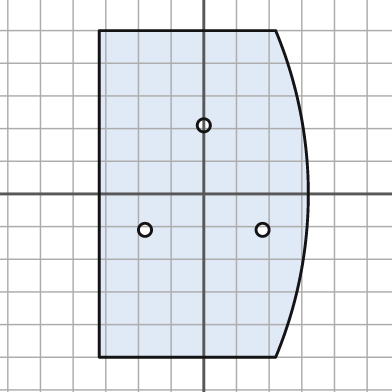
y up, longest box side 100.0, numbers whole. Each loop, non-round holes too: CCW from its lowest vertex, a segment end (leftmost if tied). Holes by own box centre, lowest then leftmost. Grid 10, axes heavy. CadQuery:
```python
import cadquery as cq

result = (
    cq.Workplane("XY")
    .moveTo(-32.0, -50.0)
    .lineTo(22.0, -50.0)
    .threePointArc((32.0, 0.0), (22.0, 50.0))
    .lineTo(-32.0, 50.0)
    .close()
    .moveTo(-18.0, -11.0)
    .circle(2.0)
    .moveTo(18.0, -11.0)
    .circle(2.0)
    .moveTo(0.0, 21.0)
    .circle(2.0)
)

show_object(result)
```